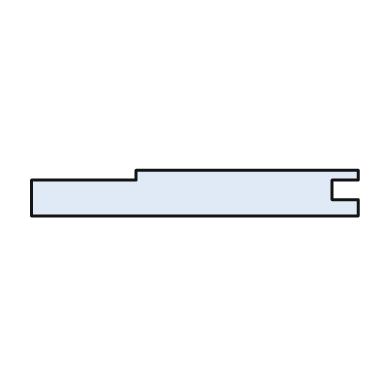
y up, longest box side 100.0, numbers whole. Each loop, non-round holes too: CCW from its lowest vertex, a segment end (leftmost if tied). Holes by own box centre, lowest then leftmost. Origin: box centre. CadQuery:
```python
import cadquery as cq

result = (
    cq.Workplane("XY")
    .moveTo(-50.0, -7.0)
    .lineTo(50.0, -7.0)
    .lineTo(50.0, -2.0)
    .lineTo(42.0, -2.0)
    .lineTo(42.0, 4.0)
    .lineTo(50.0, 4.0)
    .lineTo(50.0, 7.0)
    .lineTo(-18.0, 7.0)
    .lineTo(-18.0, 4.0)
    .lineTo(-50.0, 4.0)
    .close()
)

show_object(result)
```